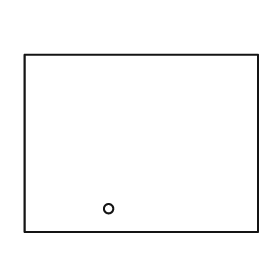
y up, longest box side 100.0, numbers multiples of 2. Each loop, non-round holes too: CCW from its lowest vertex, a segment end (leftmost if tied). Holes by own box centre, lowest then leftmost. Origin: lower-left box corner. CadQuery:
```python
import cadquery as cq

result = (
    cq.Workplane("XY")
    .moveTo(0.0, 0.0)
    .lineTo(100.0, 0.0)
    .lineTo(100.0, 76.0)
    .lineTo(0.0, 76.0)
    .close()
    .moveTo(36.0, 10.0)
    .circle(2.0)
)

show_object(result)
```